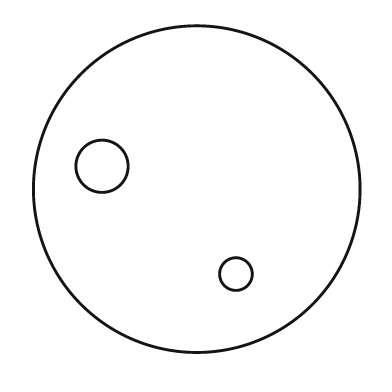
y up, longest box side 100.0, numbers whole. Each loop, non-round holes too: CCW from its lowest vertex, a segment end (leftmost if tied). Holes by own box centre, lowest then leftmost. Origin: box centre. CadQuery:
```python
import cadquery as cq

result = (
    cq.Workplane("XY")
    .moveTo(0.0, 0.0)
    .circle(50.0)
    .moveTo(12.0, -26.0)
    .circle(5.0)
    .moveTo(-29.0, 7.0)
    .circle(8.0)
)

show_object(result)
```